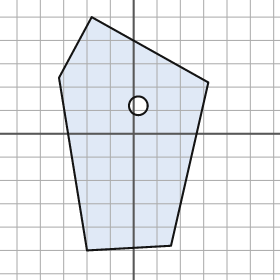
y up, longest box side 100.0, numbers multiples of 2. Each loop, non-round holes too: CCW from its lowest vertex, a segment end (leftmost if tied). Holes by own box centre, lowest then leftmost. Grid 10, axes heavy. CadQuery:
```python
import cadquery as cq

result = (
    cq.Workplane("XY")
    .moveTo(-20.0, -50.0)
    .lineTo(16.0, -48.0)
    .lineTo(32.0, 22.0)
    .lineTo(-18.0, 50.0)
    .lineTo(-32.0, 24.0)
    .close()
    .moveTo(2.0, 12.0)
    .circle(4.0)
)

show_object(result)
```